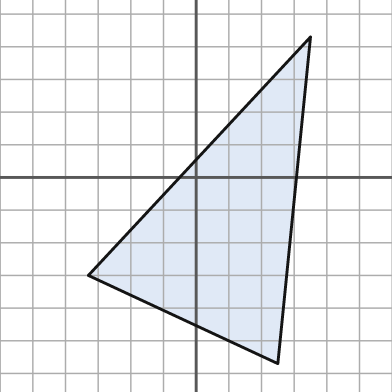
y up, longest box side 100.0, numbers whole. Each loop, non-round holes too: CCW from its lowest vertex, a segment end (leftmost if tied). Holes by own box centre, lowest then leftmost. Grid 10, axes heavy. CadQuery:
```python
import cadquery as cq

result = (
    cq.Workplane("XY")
    .moveTo(25.0, -57.0)
    .lineTo(35.0, 43.0)
    .lineTo(-33.0, -30.0)
    .close()
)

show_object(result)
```